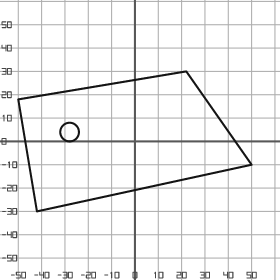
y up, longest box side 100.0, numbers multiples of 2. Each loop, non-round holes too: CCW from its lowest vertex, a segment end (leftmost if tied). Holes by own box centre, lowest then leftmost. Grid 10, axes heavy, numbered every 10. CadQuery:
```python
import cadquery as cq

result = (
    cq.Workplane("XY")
    .moveTo(-42.0, -30.0)
    .lineTo(50.0, -10.0)
    .lineTo(22.0, 30.0)
    .lineTo(-50.0, 18.0)
    .close()
    .moveTo(-28.0, 4.0)
    .circle(4.0)
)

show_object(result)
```